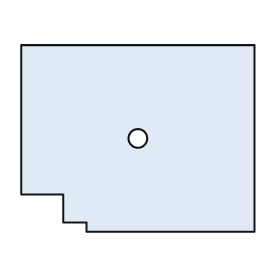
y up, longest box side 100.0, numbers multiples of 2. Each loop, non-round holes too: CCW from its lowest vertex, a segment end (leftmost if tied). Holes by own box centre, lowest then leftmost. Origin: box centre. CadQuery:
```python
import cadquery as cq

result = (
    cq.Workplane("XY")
    .moveTo(-22.0, -40.0)
    .lineTo(50.0, -40.0)
    .lineTo(50.0, 40.0)
    .lineTo(-50.0, 40.0)
    .lineTo(-50.0, -24.0)
    .lineTo(-32.0, -24.0)
    .lineTo(-32.0, -36.0)
    .lineTo(-22.0, -36.0)
    .close()
    .moveTo(0.0, 0.0)
    .circle(4.0)
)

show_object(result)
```